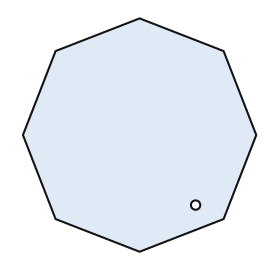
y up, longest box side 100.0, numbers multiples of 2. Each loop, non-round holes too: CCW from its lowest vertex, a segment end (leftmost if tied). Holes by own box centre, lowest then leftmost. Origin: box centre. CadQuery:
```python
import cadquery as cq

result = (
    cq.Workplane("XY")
    .moveTo(0.0, -50.0)
    .lineTo(36.0, -36.0)
    .lineTo(50.0, 0.0)
    .lineTo(36.0, 36.0)
    .lineTo(0.0, 50.0)
    .lineTo(-36.0, 36.0)
    .lineTo(-50.0, 0.0)
    .lineTo(-36.0, -36.0)
    .close()
    .moveTo(24.0, -30.0)
    .circle(2.0)
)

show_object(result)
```